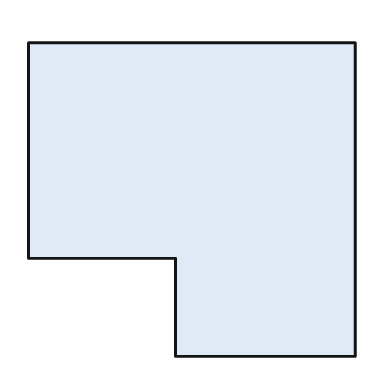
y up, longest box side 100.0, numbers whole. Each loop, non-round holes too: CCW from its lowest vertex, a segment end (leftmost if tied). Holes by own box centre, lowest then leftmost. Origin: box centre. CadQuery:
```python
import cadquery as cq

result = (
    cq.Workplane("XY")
    .moveTo(-5.0, -48.0)
    .lineTo(50.0, -48.0)
    .lineTo(50.0, 48.0)
    .lineTo(-50.0, 48.0)
    .lineTo(-50.0, -18.0)
    .lineTo(-5.0, -18.0)
    .close()
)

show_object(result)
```